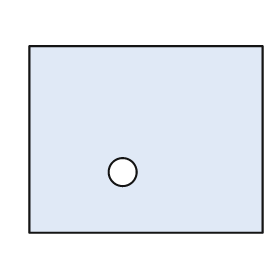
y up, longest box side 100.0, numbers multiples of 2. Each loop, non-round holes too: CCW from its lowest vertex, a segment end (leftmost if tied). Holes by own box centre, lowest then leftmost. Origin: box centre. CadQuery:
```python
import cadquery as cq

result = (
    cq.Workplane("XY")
    .moveTo(-50.0, -40.0)
    .lineTo(50.0, -40.0)
    .lineTo(50.0, 40.0)
    .lineTo(-50.0, 40.0)
    .close()
    .moveTo(-10.0, -14.0)
    .circle(6.0)
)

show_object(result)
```